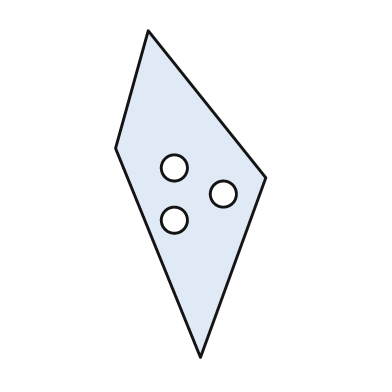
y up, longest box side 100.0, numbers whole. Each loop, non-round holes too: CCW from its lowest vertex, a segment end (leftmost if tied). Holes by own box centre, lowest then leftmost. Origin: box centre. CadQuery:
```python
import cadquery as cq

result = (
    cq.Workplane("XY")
    .moveTo(3.0, -50.0)
    .lineTo(23.0, 5.0)
    .lineTo(-13.0, 50.0)
    .lineTo(-23.0, 14.0)
    .close()
    .moveTo(-5.0, -8.0)
    .circle(4.0)
    .moveTo(10.0, 0.0)
    .circle(4.0)
    .moveTo(-5.0, 8.0)
    .circle(4.0)
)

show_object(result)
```